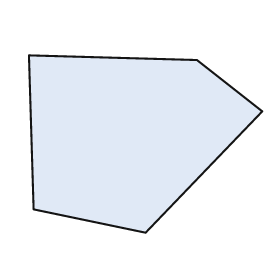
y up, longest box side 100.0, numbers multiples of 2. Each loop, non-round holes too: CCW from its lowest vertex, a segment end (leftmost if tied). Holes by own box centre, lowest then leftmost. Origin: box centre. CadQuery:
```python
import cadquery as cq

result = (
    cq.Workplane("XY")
    .moveTo(0.0, -38.0)
    .lineTo(50.0, 14.0)
    .lineTo(22.0, 36.0)
    .lineTo(-50.0, 38.0)
    .lineTo(-48.0, -28.0)
    .close()
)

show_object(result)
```